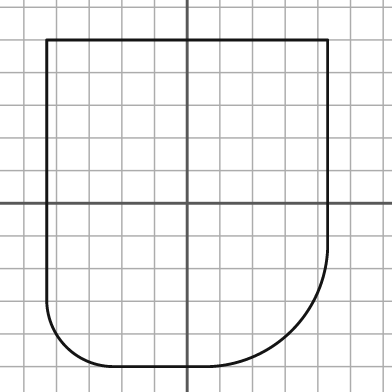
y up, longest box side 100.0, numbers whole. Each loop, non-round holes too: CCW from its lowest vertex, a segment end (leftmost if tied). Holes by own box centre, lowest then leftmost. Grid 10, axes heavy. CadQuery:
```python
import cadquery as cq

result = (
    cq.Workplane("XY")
    .moveTo(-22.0, -50.0)
    .lineTo(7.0, -50.0)
    .threePointArc((32.0, -39.0), (43.0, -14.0))
    .lineTo(43.0, 50.0)
    .lineTo(-43.0, 50.0)
    .lineTo(-43.0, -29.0)
    .threePointArc((-37.0, -44.0), (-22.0, -50.0))
    .close()
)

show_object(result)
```